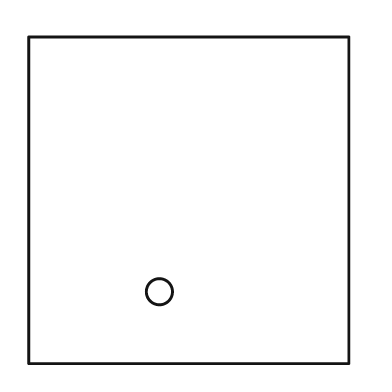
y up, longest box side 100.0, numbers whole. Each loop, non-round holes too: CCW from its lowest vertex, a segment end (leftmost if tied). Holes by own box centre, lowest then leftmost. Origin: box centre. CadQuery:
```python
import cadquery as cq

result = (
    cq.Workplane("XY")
    .moveTo(-49.0, -50.0)
    .lineTo(49.0, -50.0)
    .lineTo(49.0, 50.0)
    .lineTo(-49.0, 50.0)
    .close()
    .moveTo(-9.0, -28.0)
    .circle(4.0)
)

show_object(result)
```